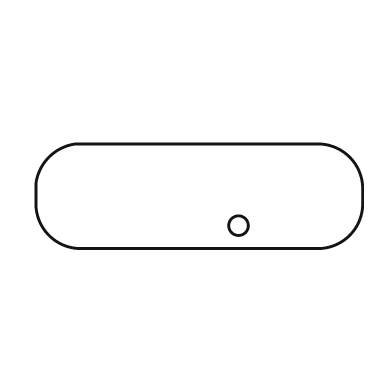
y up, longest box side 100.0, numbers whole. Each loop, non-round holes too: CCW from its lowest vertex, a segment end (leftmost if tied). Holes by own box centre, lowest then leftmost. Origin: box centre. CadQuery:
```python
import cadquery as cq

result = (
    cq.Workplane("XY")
    .moveTo(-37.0, -16.0)
    .lineTo(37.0, -16.0)
    .threePointArc((46.0, -12.0), (50.0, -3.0))
    .lineTo(50.0, 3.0)
    .threePointArc((46.0, 12.0), (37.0, 16.0))
    .lineTo(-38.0, 16.0)
    .threePointArc((-46.0, 12.0), (-50.0, 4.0))
    .lineTo(-50.0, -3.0)
    .threePointArc((-46.0, -12.0), (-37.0, -16.0))
    .close()
    .moveTo(12.0, -9.0)
    .circle(3.0)
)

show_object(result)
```